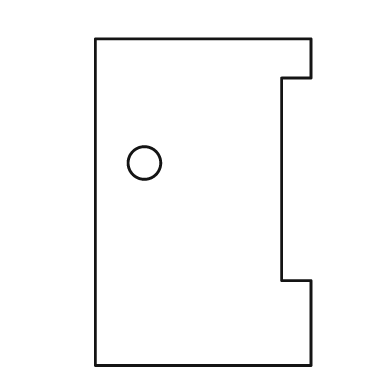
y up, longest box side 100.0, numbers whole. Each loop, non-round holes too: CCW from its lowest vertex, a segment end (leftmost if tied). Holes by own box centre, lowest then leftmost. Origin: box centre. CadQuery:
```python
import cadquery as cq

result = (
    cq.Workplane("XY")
    .moveTo(-33.0, -50.0)
    .lineTo(33.0, -50.0)
    .lineTo(33.0, -24.0)
    .lineTo(24.0, -24.0)
    .lineTo(24.0, 38.0)
    .lineTo(33.0, 38.0)
    .lineTo(33.0, 50.0)
    .lineTo(-33.0, 50.0)
    .close()
    .moveTo(-18.0, 12.0)
    .circle(5.0)
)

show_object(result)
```